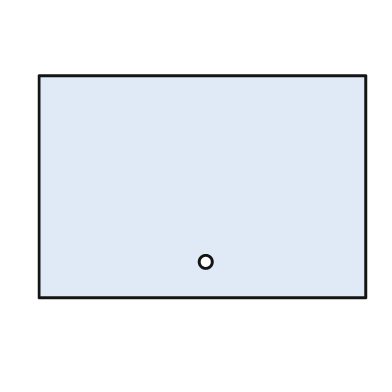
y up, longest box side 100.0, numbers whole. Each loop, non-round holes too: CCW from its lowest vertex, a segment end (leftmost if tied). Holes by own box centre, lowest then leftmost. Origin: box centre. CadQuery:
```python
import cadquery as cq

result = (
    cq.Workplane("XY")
    .moveTo(-50.0, -34.0)
    .lineTo(50.0, -34.0)
    .lineTo(50.0, 34.0)
    .lineTo(-50.0, 34.0)
    .close()
    .moveTo(1.0, -23.0)
    .circle(2.0)
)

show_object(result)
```